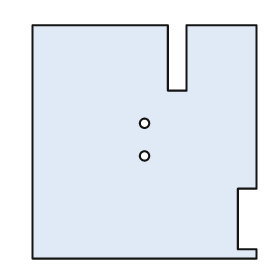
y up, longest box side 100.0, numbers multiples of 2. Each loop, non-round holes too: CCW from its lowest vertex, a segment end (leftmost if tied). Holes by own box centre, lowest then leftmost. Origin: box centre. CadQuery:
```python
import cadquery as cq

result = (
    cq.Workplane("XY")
    .moveTo(-48.0, -50.0)
    .lineTo(48.0, -50.0)
    .lineTo(48.0, -46.0)
    .lineTo(40.0, -46.0)
    .lineTo(40.0, -20.0)
    .lineTo(48.0, -20.0)
    .lineTo(48.0, 50.0)
    .lineTo(18.0, 50.0)
    .lineTo(18.0, 22.0)
    .lineTo(10.0, 22.0)
    .lineTo(10.0, 50.0)
    .lineTo(-48.0, 50.0)
    .close()
    .moveTo(0.0, -6.0)
    .circle(2.0)
    .moveTo(0.0, 8.0)
    .circle(2.0)
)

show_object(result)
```